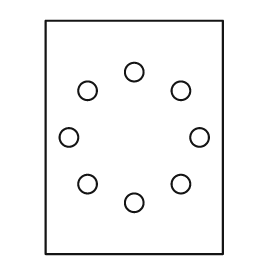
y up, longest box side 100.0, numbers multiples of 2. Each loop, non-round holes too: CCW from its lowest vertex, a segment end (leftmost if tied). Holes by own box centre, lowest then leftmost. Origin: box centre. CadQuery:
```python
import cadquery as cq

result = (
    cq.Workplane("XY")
    .moveTo(-38.0, -50.0)
    .lineTo(38.0, -50.0)
    .lineTo(38.0, 50.0)
    .lineTo(-38.0, 50.0)
    .close()
    .moveTo(0.0, -28.0)
    .circle(4.0)
    .moveTo(-20.0, -20.0)
    .circle(4.0)
    .moveTo(20.0, -20.0)
    .circle(4.0)
    .moveTo(-28.0, 0.0)
    .circle(4.0)
    .moveTo(28.0, 0.0)
    .circle(4.0)
    .moveTo(-20.0, 20.0)
    .circle(4.0)
    .moveTo(20.0, 20.0)
    .circle(4.0)
    .moveTo(0.0, 28.0)
    .circle(4.0)
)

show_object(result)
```